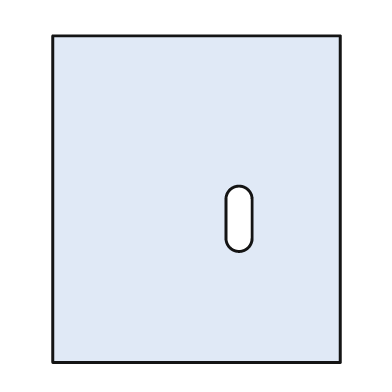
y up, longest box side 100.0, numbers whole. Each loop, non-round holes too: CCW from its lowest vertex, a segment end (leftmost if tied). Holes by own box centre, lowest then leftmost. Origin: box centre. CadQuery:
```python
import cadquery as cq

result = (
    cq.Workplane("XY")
    .moveTo(-44.0, -50.0)
    .lineTo(44.0, -50.0)
    .lineTo(44.0, 50.0)
    .lineTo(-44.0, 50.0)
    .close()
    .moveTo(9.0, -12.0)
    .threePointArc((13.0, -16.0), (17.0, -12.0))
    .lineTo(17.0, 0.0)
    .threePointArc((13.0, 4.0), (9.0, 0.0))
    .close()
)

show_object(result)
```